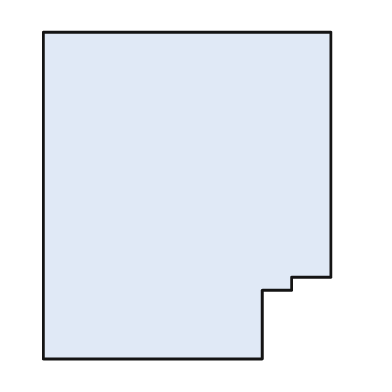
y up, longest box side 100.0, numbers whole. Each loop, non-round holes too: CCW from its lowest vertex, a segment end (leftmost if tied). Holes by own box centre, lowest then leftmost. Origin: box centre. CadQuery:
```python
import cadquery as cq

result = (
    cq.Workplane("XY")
    .moveTo(-44.0, -50.0)
    .lineTo(23.0, -50.0)
    .lineTo(23.0, -29.0)
    .lineTo(32.0, -29.0)
    .lineTo(32.0, -25.0)
    .lineTo(44.0, -25.0)
    .lineTo(44.0, 50.0)
    .lineTo(-44.0, 50.0)
    .close()
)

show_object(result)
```